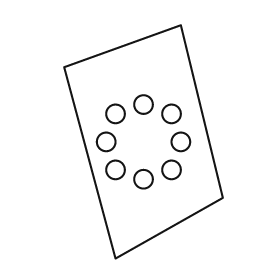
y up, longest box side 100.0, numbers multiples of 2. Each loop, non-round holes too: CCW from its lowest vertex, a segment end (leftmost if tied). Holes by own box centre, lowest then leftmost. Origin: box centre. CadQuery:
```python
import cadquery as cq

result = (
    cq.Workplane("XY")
    .moveTo(-12.0, -50.0)
    .lineTo(34.0, -24.0)
    .lineTo(16.0, 50.0)
    .lineTo(-34.0, 32.0)
    .close()
    .moveTo(0.0, -16.0)
    .circle(4.0)
    .moveTo(-12.0, -12.0)
    .circle(4.0)
    .moveTo(12.0, -12.0)
    .circle(4.0)
    .moveTo(-16.0, 0.0)
    .circle(4.0)
    .moveTo(16.0, 0.0)
    .circle(4.0)
    .moveTo(-12.0, 12.0)
    .circle(4.0)
    .moveTo(12.0, 12.0)
    .circle(4.0)
    .moveTo(0.0, 16.0)
    .circle(4.0)
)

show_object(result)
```